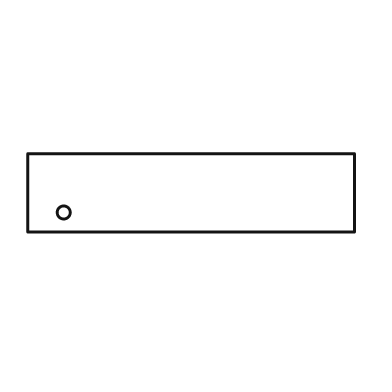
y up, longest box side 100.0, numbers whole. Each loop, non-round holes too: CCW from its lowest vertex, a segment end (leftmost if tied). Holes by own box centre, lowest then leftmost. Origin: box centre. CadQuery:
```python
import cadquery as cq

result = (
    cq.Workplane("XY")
    .moveTo(-50.0, -12.0)
    .lineTo(50.0, -12.0)
    .lineTo(50.0, 12.0)
    .lineTo(-50.0, 12.0)
    .close()
    .moveTo(-39.0, -6.0)
    .circle(2.0)
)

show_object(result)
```